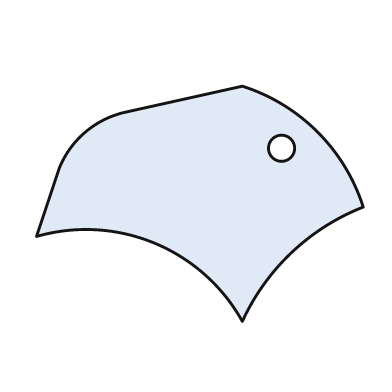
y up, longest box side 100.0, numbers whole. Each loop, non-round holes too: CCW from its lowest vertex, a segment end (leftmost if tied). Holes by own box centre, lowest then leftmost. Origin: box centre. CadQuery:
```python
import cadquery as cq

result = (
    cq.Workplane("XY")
    .moveTo(13.0, -36.0)
    .threePointArc((28.0, -15.0), (50.0, -1.0))
    .threePointArc((36.0, 22.0), (13.0, 36.0))
    .lineTo(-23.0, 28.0)
    .threePointArc((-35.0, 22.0), (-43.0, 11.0))
    .lineTo(-50.0, -10.0)
    .threePointArc((-14.0, -12.0), (13.0, -36.0))
    .close()
    .moveTo(25.0, 17.0)
    .circle(4.0)
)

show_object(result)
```